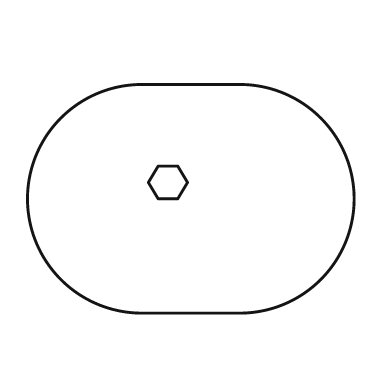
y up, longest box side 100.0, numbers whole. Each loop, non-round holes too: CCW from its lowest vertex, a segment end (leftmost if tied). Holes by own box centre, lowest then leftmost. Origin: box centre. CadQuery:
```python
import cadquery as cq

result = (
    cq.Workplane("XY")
    .moveTo(-15.0, -35.0)
    .lineTo(15.0, -35.0)
    .threePointArc((50.0, 0.0), (15.0, 35.0))
    .lineTo(-15.0, 35.0)
    .threePointArc((-50.0, 0.0), (-15.0, -35.0))
    .close()
    .moveTo(-10.0, 0.0)
    .lineTo(-4.0, 0.0)
    .lineTo(-1.0, 5.0)
    .lineTo(-4.0, 10.0)
    .lineTo(-10.0, 10.0)
    .lineTo(-13.0, 5.0)
    .close()
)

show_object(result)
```